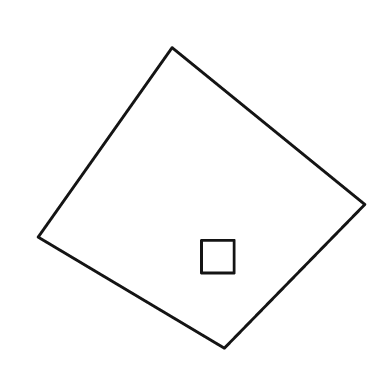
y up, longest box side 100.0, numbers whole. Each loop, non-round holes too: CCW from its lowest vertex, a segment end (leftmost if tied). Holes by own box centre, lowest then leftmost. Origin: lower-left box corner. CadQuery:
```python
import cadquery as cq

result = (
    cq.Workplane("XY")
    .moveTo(57.0, 0.0)
    .lineTo(100.0, 44.0)
    .lineTo(41.0, 92.0)
    .lineTo(0.0, 34.0)
    .close()
    .moveTo(50.0, 23.0)
    .lineTo(60.0, 23.0)
    .lineTo(60.0, 33.0)
    .lineTo(50.0, 33.0)
    .close()
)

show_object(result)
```